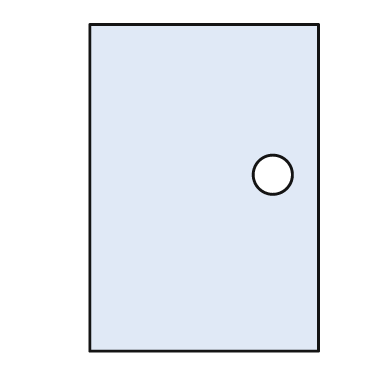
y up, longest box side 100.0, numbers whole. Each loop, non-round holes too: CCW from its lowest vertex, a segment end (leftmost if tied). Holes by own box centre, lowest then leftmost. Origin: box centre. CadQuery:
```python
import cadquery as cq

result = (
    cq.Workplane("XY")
    .moveTo(-35.0, -50.0)
    .lineTo(35.0, -50.0)
    .lineTo(35.0, 50.0)
    .lineTo(-35.0, 50.0)
    .close()
    .moveTo(21.0, 4.0)
    .circle(6.0)
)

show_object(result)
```